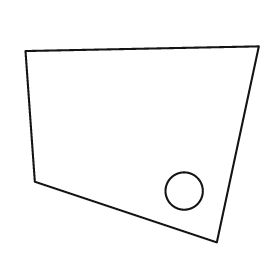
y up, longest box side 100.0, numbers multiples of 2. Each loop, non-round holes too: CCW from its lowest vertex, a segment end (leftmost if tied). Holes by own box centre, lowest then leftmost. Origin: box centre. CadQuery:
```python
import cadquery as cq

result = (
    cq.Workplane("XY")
    .moveTo(32.0, -42.0)
    .lineTo(50.0, 42.0)
    .lineTo(-50.0, 40.0)
    .lineTo(-46.0, -16.0)
    .close()
    .moveTo(18.0, -20.0)
    .circle(8.0)
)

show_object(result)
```